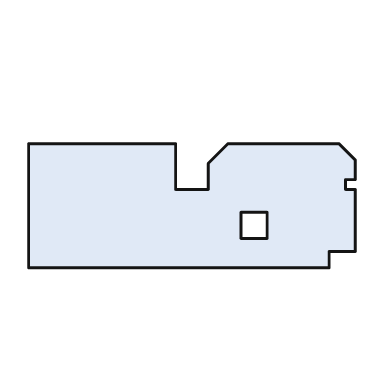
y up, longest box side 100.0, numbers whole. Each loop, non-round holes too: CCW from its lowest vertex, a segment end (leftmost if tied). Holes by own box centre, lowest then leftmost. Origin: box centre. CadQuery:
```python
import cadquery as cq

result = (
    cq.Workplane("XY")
    .moveTo(-50.0, -19.0)
    .lineTo(42.0, -19.0)
    .lineTo(42.0, -14.0)
    .lineTo(50.0, -14.0)
    .lineTo(50.0, 5.0)
    .lineTo(47.0, 5.0)
    .lineTo(47.0, 8.0)
    .lineTo(50.0, 8.0)
    .lineTo(50.0, 14.0)
    .lineTo(45.0, 19.0)
    .lineTo(11.0, 19.0)
    .lineTo(5.0, 13.0)
    .lineTo(5.0, 5.0)
    .lineTo(-5.0, 5.0)
    .lineTo(-5.0, 19.0)
    .lineTo(-50.0, 19.0)
    .close()
    .moveTo(15.0, -10.0)
    .lineTo(23.0, -10.0)
    .lineTo(23.0, -2.0)
    .lineTo(15.0, -2.0)
    .close()
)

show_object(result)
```